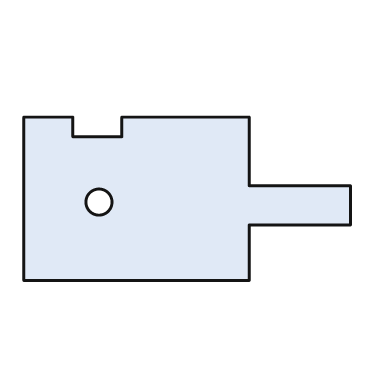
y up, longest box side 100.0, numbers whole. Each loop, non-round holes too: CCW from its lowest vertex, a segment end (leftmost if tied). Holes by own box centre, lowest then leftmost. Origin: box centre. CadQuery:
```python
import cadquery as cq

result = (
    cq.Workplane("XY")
    .moveTo(-50.0, -25.0)
    .lineTo(19.0, -25.0)
    .lineTo(19.0, -8.0)
    .lineTo(50.0, -8.0)
    .lineTo(50.0, 4.0)
    .lineTo(19.0, 4.0)
    .lineTo(19.0, 25.0)
    .lineTo(-20.0, 25.0)
    .lineTo(-20.0, 19.0)
    .lineTo(-35.0, 19.0)
    .lineTo(-35.0, 25.0)
    .lineTo(-50.0, 25.0)
    .close()
    .moveTo(-27.0, -1.0)
    .circle(4.0)
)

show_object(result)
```